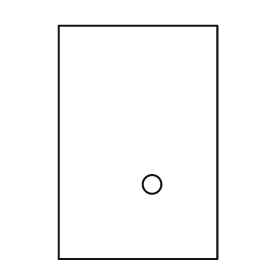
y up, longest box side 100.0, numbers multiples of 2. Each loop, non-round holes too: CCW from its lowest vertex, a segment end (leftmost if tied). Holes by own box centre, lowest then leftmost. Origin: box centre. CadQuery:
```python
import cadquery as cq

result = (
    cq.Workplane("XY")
    .moveTo(-34.0, -50.0)
    .lineTo(34.0, -50.0)
    .lineTo(34.0, 50.0)
    .lineTo(-34.0, 50.0)
    .close()
    .moveTo(6.0, -18.0)
    .circle(4.0)
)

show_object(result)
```